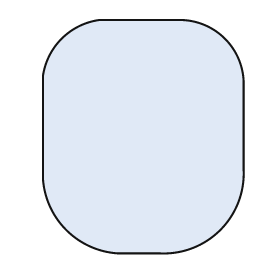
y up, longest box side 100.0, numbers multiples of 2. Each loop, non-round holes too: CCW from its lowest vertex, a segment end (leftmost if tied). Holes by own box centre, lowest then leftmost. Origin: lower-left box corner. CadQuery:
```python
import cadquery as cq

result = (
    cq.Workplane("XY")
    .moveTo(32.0, 0.0)
    .lineTo(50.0, 0.0)
    .threePointArc((76.0, 10.0), (86.0, 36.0))
    .lineTo(86.0, 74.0)
    .threePointArc((78.0, 92.0), (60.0, 100.0))
    .lineTo(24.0, 100.0)
    .threePointArc((8.0, 92.0), (0.0, 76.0))
    .lineTo(0.0, 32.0)
    .threePointArc((10.0, 10.0), (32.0, 0.0))
    .close()
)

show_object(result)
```